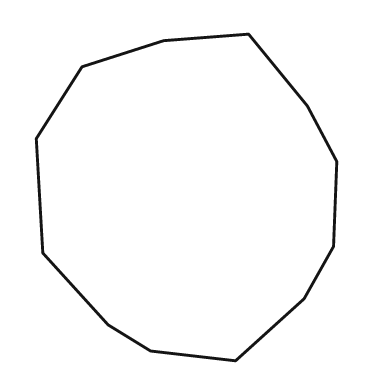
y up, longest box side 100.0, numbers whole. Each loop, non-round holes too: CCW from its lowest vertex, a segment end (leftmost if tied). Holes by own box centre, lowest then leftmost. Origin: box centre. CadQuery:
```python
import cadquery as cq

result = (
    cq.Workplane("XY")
    .moveTo(15.0, -50.0)
    .lineTo(36.0, -31.0)
    .lineTo(45.0, -15.0)
    .lineTo(46.0, 11.0)
    .lineTo(37.0, 28.0)
    .lineTo(19.0, 50.0)
    .lineTo(-7.0, 48.0)
    .lineTo(-32.0, 40.0)
    .lineTo(-46.0, 18.0)
    .lineTo(-44.0, -17.0)
    .lineTo(-24.0, -39.0)
    .lineTo(-11.0, -47.0)
    .close()
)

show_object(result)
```